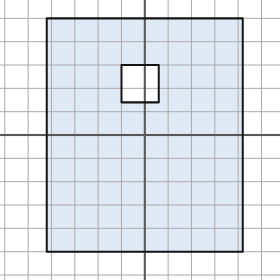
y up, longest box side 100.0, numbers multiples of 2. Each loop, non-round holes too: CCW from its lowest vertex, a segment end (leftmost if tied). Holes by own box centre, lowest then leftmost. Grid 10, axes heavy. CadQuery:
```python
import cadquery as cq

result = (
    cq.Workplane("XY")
    .moveTo(-42.0, -50.0)
    .lineTo(42.0, -50.0)
    .lineTo(42.0, 50.0)
    .lineTo(-42.0, 50.0)
    .close()
    .moveTo(-10.0, 14.0)
    .lineTo(6.0, 14.0)
    .lineTo(6.0, 30.0)
    .lineTo(-10.0, 30.0)
    .close()
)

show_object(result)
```